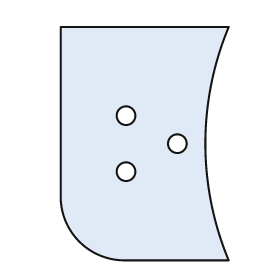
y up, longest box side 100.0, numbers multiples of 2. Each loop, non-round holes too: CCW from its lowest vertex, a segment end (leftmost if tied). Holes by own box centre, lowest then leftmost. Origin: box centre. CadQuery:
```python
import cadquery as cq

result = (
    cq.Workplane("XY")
    .moveTo(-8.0, -50.0)
    .lineTo(36.0, -50.0)
    .threePointArc((26.0, 0.0), (36.0, 50.0))
    .lineTo(-36.0, 50.0)
    .lineTo(-36.0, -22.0)
    .threePointArc((-28.0, -42.0), (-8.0, -50.0))
    .close()
    .moveTo(-8.0, -12.0)
    .circle(4.0)
    .moveTo(14.0, 0.0)
    .circle(4.0)
    .moveTo(-8.0, 12.0)
    .circle(4.0)
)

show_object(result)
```